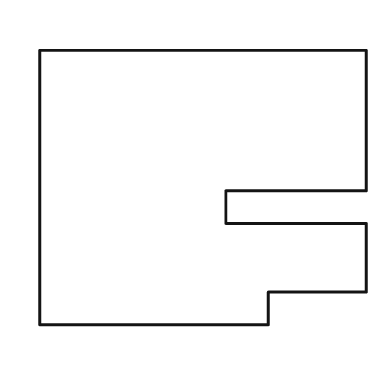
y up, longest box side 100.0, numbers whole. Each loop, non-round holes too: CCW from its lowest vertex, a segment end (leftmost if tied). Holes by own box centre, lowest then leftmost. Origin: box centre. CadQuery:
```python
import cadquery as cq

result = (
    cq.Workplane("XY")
    .moveTo(-50.0, -42.0)
    .lineTo(20.0, -42.0)
    .lineTo(20.0, -32.0)
    .lineTo(50.0, -32.0)
    .lineTo(50.0, -11.0)
    .lineTo(7.0, -11.0)
    .lineTo(7.0, -1.0)
    .lineTo(50.0, -1.0)
    .lineTo(50.0, 42.0)
    .lineTo(-50.0, 42.0)
    .close()
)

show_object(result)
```